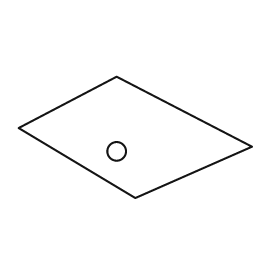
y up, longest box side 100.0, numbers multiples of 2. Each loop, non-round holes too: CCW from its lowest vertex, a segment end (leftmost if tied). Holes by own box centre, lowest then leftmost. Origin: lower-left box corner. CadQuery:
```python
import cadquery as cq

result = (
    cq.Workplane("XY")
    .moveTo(50.0, 0.0)
    .lineTo(100.0, 22.0)
    .lineTo(42.0, 52.0)
    .lineTo(0.0, 30.0)
    .close()
    .moveTo(42.0, 20.0)
    .circle(4.0)
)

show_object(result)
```